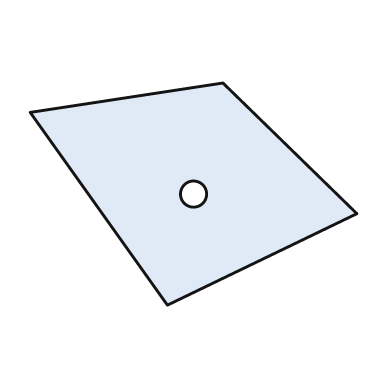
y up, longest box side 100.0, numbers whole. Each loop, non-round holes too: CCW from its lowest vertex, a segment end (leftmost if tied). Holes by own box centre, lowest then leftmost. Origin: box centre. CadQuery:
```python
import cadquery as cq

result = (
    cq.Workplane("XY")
    .moveTo(-8.0, -34.0)
    .lineTo(50.0, -6.0)
    .lineTo(9.0, 34.0)
    .lineTo(-50.0, 25.0)
    .close()
    .moveTo(0.0, 0.0)
    .circle(4.0)
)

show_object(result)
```